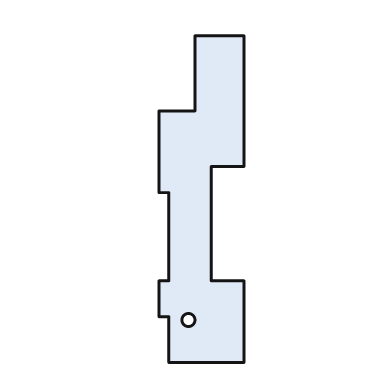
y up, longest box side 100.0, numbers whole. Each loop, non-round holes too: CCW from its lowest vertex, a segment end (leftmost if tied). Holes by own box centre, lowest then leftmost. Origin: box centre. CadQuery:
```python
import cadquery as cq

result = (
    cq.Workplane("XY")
    .moveTo(-10.0, -50.0)
    .lineTo(13.0, -50.0)
    .lineTo(13.0, -25.0)
    .lineTo(3.0, -25.0)
    .lineTo(3.0, 10.0)
    .lineTo(13.0, 10.0)
    .lineTo(13.0, 50.0)
    .lineTo(-2.0, 50.0)
    .lineTo(-2.0, 27.0)
    .lineTo(-13.0, 27.0)
    .lineTo(-13.0, 2.0)
    .lineTo(-10.0, 2.0)
    .lineTo(-10.0, -25.0)
    .lineTo(-13.0, -25.0)
    .lineTo(-13.0, -36.0)
    .lineTo(-10.0, -36.0)
    .close()
    .moveTo(-4.0, -37.0)
    .circle(2.0)
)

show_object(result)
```